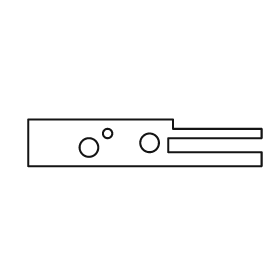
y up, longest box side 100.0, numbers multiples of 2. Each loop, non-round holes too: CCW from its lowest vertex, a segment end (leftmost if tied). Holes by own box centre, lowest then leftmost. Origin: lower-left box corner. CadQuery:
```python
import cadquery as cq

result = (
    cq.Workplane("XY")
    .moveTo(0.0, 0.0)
    .lineTo(100.0, 0.0)
    .lineTo(100.0, 6.0)
    .lineTo(60.0, 6.0)
    .lineTo(60.0, 12.0)
    .lineTo(100.0, 12.0)
    .lineTo(100.0, 16.0)
    .lineTo(62.0, 16.0)
    .lineTo(62.0, 20.0)
    .lineTo(0.0, 20.0)
    .close()
    .moveTo(26.0, 8.0)
    .circle(4.0)
    .moveTo(52.0, 10.0)
    .circle(4.0)
    .moveTo(34.0, 14.0)
    .circle(2.0)
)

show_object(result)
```